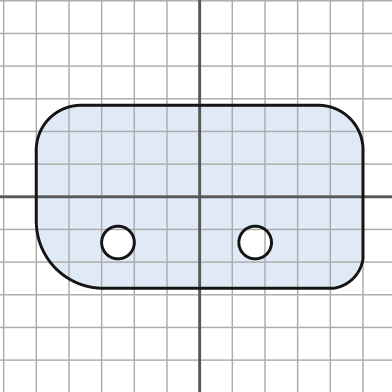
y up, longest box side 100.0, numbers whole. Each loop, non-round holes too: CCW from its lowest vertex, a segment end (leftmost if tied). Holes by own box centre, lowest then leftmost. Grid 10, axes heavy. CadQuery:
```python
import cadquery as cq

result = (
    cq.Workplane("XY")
    .moveTo(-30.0, -28.0)
    .lineTo(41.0, -28.0)
    .threePointArc((47.0, -25.0), (50.0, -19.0))
    .lineTo(50.0, 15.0)
    .threePointArc((46.0, 24.0), (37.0, 28.0))
    .lineTo(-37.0, 28.0)
    .threePointArc((-46.0, 24.0), (-50.0, 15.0))
    .lineTo(-50.0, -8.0)
    .threePointArc((-44.0, -22.0), (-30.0, -28.0))
    .close()
    .moveTo(-25.0, -14.0)
    .circle(5.0)
    .moveTo(17.0, -14.0)
    .circle(5.0)
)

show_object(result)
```